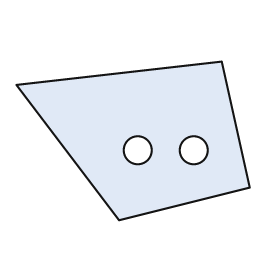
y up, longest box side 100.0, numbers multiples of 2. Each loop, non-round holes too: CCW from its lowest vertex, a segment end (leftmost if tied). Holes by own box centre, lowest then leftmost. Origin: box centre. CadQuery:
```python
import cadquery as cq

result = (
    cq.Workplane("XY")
    .moveTo(-6.0, -34.0)
    .lineTo(50.0, -20.0)
    .lineTo(38.0, 34.0)
    .lineTo(-50.0, 24.0)
    .close()
    .moveTo(2.0, -4.0)
    .circle(6.0)
    .moveTo(26.0, -4.0)
    .circle(6.0)
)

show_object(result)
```